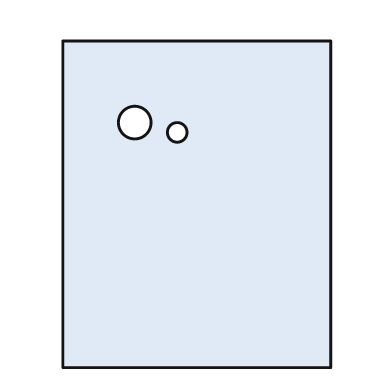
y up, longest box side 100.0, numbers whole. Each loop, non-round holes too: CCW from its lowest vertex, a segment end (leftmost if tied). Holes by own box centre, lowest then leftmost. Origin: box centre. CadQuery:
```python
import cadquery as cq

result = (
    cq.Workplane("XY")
    .moveTo(-41.0, -50.0)
    .lineTo(41.0, -50.0)
    .lineTo(41.0, 50.0)
    .lineTo(-41.0, 50.0)
    .close()
    .moveTo(-6.0, 22.0)
    .circle(3.0)
    .moveTo(-19.0, 25.0)
    .circle(5.0)
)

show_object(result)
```